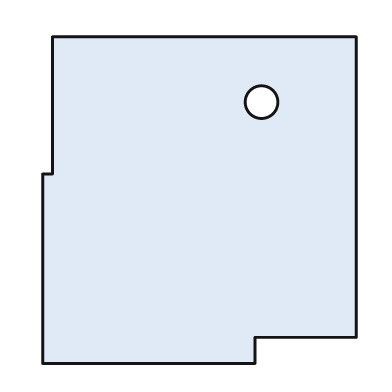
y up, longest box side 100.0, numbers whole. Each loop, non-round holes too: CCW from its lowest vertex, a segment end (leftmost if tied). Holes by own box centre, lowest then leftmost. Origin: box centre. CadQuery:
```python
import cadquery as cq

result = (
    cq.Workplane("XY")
    .moveTo(-48.0, -50.0)
    .lineTo(17.0, -50.0)
    .lineTo(17.0, -42.0)
    .lineTo(48.0, -42.0)
    .lineTo(48.0, 50.0)
    .lineTo(-45.0, 50.0)
    .lineTo(-45.0, 8.0)
    .lineTo(-48.0, 8.0)
    .close()
    .moveTo(19.0, 30.0)
    .circle(5.0)
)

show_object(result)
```